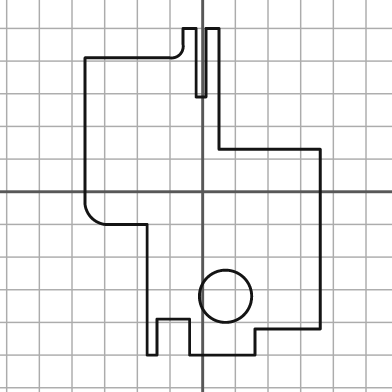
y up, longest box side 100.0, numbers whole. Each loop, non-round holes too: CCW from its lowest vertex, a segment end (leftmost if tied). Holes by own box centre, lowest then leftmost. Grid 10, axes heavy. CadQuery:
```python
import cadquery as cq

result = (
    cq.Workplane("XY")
    .moveTo(-17.0, -50.0)
    .lineTo(-14.0, -50.0)
    .lineTo(-14.0, -39.0)
    .lineTo(-4.0, -39.0)
    .lineTo(-4.0, -50.0)
    .lineTo(16.0, -50.0)
    .lineTo(16.0, -42.0)
    .lineTo(36.0, -42.0)
    .lineTo(36.0, 13.0)
    .lineTo(5.0, 13.0)
    .lineTo(5.0, 50.0)
    .lineTo(1.0, 50.0)
    .lineTo(1.0, 29.0)
    .lineTo(-2.0, 29.0)
    .lineTo(-2.0, 50.0)
    .lineTo(-6.0, 50.0)
    .lineTo(-6.0, 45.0)
    .threePointArc((-7.0, 42.0), (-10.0, 41.0))
    .lineTo(-36.0, 41.0)
    .lineTo(-36.0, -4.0)
    .threePointArc((-34.0, -8.0), (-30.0, -10.0))
    .lineTo(-17.0, -10.0)
    .close()
    .moveTo(7.0, -32.0)
    .circle(8.0)
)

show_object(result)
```